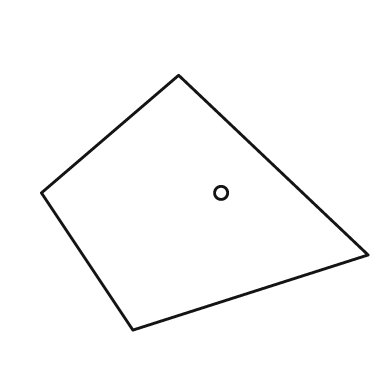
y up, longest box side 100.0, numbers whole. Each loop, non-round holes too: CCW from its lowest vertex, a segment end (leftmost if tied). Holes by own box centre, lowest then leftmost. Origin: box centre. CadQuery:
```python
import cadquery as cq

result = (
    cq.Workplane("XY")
    .moveTo(-22.0, -39.0)
    .lineTo(50.0, -16.0)
    .lineTo(-8.0, 39.0)
    .lineTo(-50.0, 3.0)
    .close()
    .moveTo(5.0, 3.0)
    .circle(2.0)
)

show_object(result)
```